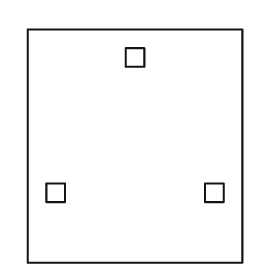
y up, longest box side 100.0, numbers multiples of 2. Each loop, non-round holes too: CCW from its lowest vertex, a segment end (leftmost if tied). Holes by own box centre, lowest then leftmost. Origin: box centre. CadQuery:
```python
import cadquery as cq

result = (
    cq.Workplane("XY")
    .moveTo(-46.0, -50.0)
    .lineTo(46.0, -50.0)
    .lineTo(46.0, 50.0)
    .lineTo(-46.0, 50.0)
    .close()
    .moveTo(-38.0, -24.0)
    .lineTo(-30.0, -24.0)
    .lineTo(-30.0, -16.0)
    .lineTo(-38.0, -16.0)
    .close()
    .moveTo(30.0, -24.0)
    .lineTo(38.0, -24.0)
    .lineTo(38.0, -16.0)
    .lineTo(30.0, -16.0)
    .close()
    .moveTo(-4.0, 34.0)
    .lineTo(4.0, 34.0)
    .lineTo(4.0, 42.0)
    .lineTo(-4.0, 42.0)
    .close()
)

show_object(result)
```